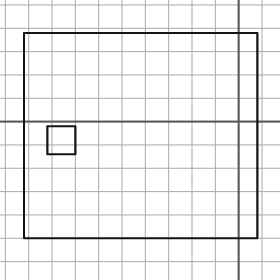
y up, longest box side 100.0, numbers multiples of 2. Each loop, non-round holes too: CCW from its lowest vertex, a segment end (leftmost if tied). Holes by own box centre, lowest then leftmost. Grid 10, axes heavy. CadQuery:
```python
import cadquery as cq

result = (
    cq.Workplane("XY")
    .moveTo(-92.0, -50.0)
    .lineTo(8.0, -50.0)
    .lineTo(8.0, 38.0)
    .lineTo(-92.0, 38.0)
    .close()
    .moveTo(-82.0, -14.0)
    .lineTo(-70.0, -14.0)
    .lineTo(-70.0, -2.0)
    .lineTo(-82.0, -2.0)
    .close()
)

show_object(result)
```